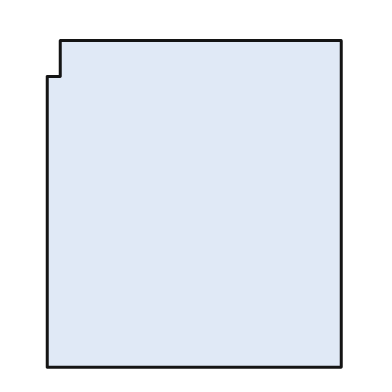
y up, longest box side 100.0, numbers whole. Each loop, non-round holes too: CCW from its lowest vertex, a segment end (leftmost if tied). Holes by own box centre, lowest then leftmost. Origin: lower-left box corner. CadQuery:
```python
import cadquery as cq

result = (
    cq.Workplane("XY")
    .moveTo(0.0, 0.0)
    .lineTo(90.0, 0.0)
    .lineTo(90.0, 100.0)
    .lineTo(4.0, 100.0)
    .lineTo(4.0, 89.0)
    .lineTo(0.0, 89.0)
    .close()
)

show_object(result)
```